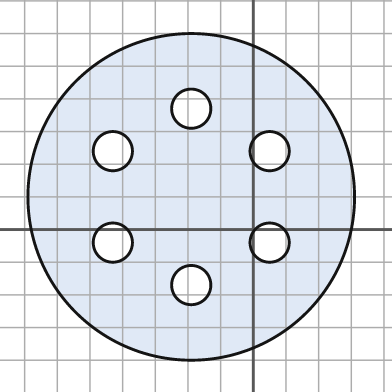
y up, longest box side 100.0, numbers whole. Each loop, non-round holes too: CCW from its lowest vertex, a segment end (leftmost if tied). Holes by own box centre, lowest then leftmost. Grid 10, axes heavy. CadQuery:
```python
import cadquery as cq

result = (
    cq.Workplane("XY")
    .moveTo(-19.0, 10.0)
    .circle(50.0)
    .moveTo(-19.0, -17.0)
    .circle(6.0)
    .moveTo(-43.0, -4.0)
    .circle(6.0)
    .moveTo(5.0, -4.0)
    .circle(6.0)
    .moveTo(-43.0, 24.0)
    .circle(6.0)
    .moveTo(5.0, 24.0)
    .circle(6.0)
    .moveTo(-19.0, 37.0)
    .circle(6.0)
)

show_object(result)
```